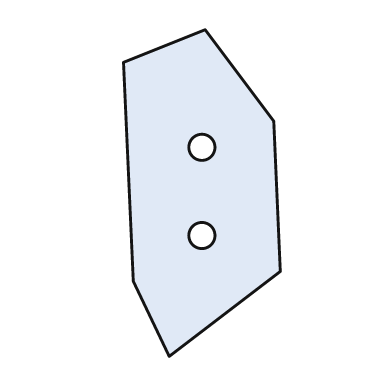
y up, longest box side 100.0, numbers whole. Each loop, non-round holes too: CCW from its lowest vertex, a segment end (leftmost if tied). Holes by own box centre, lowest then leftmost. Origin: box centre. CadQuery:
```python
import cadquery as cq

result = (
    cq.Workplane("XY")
    .moveTo(-10.0, -50.0)
    .lineTo(24.0, -24.0)
    .lineTo(22.0, 22.0)
    .lineTo(1.0, 50.0)
    .lineTo(-24.0, 40.0)
    .lineTo(-21.0, -27.0)
    .close()
    .moveTo(0.0, -13.0)
    .circle(4.0)
    .moveTo(0.0, 14.0)
    .circle(4.0)
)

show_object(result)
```